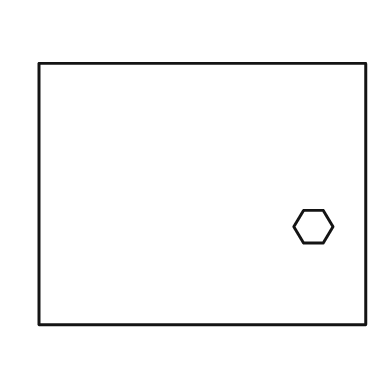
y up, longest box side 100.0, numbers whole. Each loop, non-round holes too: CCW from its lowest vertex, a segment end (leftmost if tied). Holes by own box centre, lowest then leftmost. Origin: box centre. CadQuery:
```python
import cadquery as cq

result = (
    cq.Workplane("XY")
    .moveTo(-50.0, -40.0)
    .lineTo(50.0, -40.0)
    .lineTo(50.0, 40.0)
    .lineTo(-50.0, 40.0)
    .close()
    .moveTo(31.0, -15.0)
    .lineTo(37.0, -15.0)
    .lineTo(40.0, -10.0)
    .lineTo(37.0, -5.0)
    .lineTo(31.0, -5.0)
    .lineTo(28.0, -10.0)
    .close()
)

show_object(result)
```